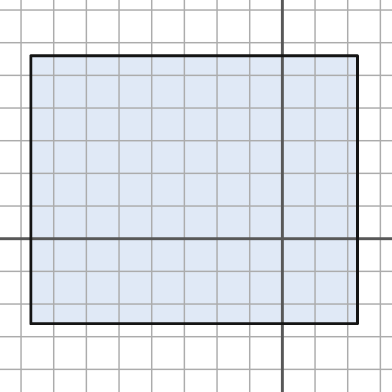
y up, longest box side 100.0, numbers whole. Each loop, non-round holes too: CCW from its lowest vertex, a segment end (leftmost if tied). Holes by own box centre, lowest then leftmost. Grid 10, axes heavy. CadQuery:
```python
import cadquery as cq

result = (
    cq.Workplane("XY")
    .moveTo(-77.0, -26.0)
    .lineTo(23.0, -26.0)
    .lineTo(23.0, 56.0)
    .lineTo(-77.0, 56.0)
    .close()
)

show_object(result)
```